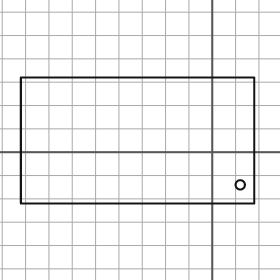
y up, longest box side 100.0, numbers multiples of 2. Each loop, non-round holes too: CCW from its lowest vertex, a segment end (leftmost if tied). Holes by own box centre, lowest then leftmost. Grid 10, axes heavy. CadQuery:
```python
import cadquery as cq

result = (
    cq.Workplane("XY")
    .moveTo(-82.0, -22.0)
    .lineTo(18.0, -22.0)
    .lineTo(18.0, 32.0)
    .lineTo(-82.0, 32.0)
    .close()
    .moveTo(12.0, -14.0)
    .circle(2.0)
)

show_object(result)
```